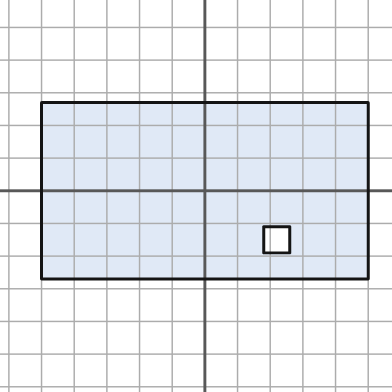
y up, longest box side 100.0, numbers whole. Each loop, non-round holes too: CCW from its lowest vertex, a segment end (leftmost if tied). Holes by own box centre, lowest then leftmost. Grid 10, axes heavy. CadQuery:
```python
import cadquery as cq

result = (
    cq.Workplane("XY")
    .moveTo(-50.0, -27.0)
    .lineTo(50.0, -27.0)
    .lineTo(50.0, 27.0)
    .lineTo(-50.0, 27.0)
    .close()
    .moveTo(18.0, -19.0)
    .lineTo(26.0, -19.0)
    .lineTo(26.0, -11.0)
    .lineTo(18.0, -11.0)
    .close()
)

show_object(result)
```